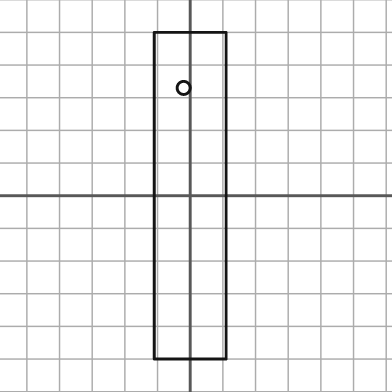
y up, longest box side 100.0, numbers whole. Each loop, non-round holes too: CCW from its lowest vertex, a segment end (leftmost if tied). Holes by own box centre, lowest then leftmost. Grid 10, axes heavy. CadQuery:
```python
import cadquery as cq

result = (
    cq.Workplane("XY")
    .moveTo(-11.0, -50.0)
    .lineTo(11.0, -50.0)
    .lineTo(11.0, 50.0)
    .lineTo(-11.0, 50.0)
    .close()
    .moveTo(-2.0, 33.0)
    .circle(2.0)
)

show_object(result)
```